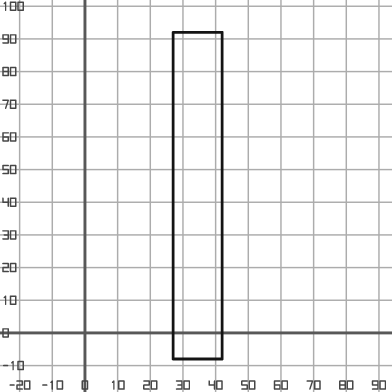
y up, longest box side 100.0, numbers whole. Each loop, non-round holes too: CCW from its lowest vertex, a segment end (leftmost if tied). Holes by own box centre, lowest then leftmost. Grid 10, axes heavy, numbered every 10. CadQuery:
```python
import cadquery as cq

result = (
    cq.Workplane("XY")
    .moveTo(27.0, -8.0)
    .lineTo(42.0, -8.0)
    .lineTo(42.0, 92.0)
    .lineTo(27.0, 92.0)
    .close()
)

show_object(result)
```